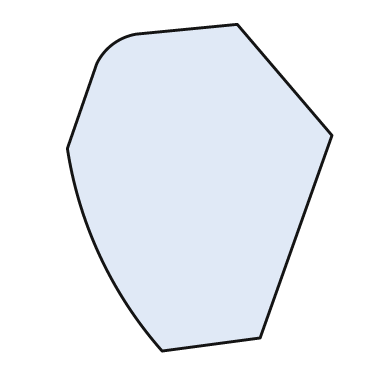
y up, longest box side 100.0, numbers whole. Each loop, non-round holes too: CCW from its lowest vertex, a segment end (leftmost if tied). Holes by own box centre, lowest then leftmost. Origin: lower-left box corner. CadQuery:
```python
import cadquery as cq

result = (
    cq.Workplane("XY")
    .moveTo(29.0, 0.0)
    .lineTo(59.0, 4.0)
    .lineTo(81.0, 66.0)
    .lineTo(52.0, 100.0)
    .lineTo(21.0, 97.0)
    .threePointArc((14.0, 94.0), (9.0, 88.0))
    .lineTo(0.0, 62.0)
    .threePointArc((10.0, 29.0), (29.0, 0.0))
    .close()
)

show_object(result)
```